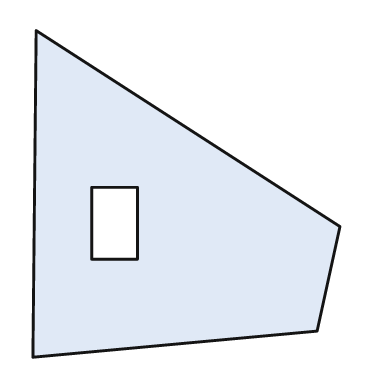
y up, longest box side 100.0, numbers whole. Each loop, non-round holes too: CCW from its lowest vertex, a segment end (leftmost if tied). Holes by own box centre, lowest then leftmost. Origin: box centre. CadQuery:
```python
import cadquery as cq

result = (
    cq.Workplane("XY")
    .moveTo(-47.0, -50.0)
    .lineTo(40.0, -42.0)
    .lineTo(47.0, -10.0)
    .lineTo(-46.0, 50.0)
    .close()
    .moveTo(-29.0, -20.0)
    .lineTo(-15.0, -20.0)
    .lineTo(-15.0, 2.0)
    .lineTo(-29.0, 2.0)
    .close()
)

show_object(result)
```